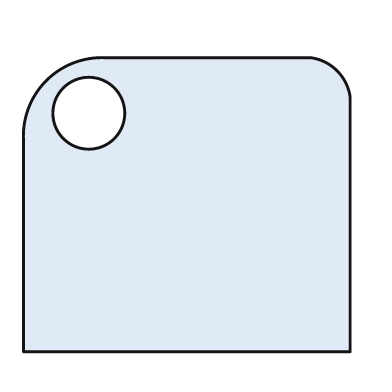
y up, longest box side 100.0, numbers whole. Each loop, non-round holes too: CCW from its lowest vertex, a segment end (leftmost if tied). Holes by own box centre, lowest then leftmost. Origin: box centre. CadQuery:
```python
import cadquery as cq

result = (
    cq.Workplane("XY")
    .moveTo(-50.0, -45.0)
    .lineTo(50.0, -45.0)
    .lineTo(50.0, 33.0)
    .threePointArc((46.0, 41.0), (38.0, 45.0))
    .lineTo(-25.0, 45.0)
    .threePointArc((-43.0, 38.0), (-50.0, 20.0))
    .close()
    .moveTo(-30.0, 28.0)
    .circle(11.0)
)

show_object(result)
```